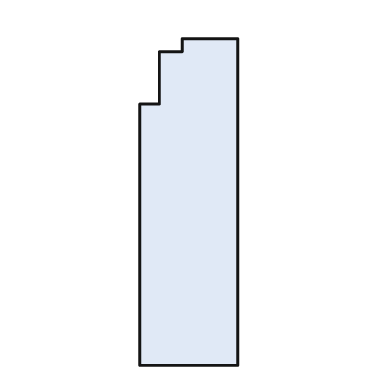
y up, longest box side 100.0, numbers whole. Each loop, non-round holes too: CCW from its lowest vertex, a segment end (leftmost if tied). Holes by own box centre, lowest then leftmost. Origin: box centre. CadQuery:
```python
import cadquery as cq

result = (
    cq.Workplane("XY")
    .moveTo(-15.0, -50.0)
    .lineTo(15.0, -50.0)
    .lineTo(15.0, 50.0)
    .lineTo(-2.0, 50.0)
    .lineTo(-2.0, 46.0)
    .lineTo(-9.0, 46.0)
    .lineTo(-9.0, 30.0)
    .lineTo(-15.0, 30.0)
    .close()
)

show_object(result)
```